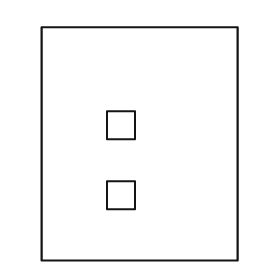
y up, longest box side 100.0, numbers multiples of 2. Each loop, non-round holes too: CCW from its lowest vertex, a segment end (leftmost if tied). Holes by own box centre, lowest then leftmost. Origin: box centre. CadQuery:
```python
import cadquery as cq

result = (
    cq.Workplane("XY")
    .moveTo(-42.0, -50.0)
    .lineTo(42.0, -50.0)
    .lineTo(42.0, 50.0)
    .lineTo(-42.0, 50.0)
    .close()
    .moveTo(-14.0, -28.0)
    .lineTo(-2.0, -28.0)
    .lineTo(-2.0, -16.0)
    .lineTo(-14.0, -16.0)
    .close()
    .moveTo(-14.0, 2.0)
    .lineTo(-2.0, 2.0)
    .lineTo(-2.0, 14.0)
    .lineTo(-14.0, 14.0)
    .close()
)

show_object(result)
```